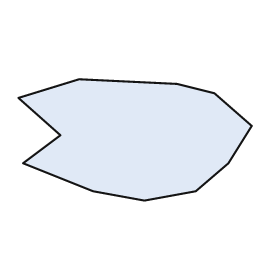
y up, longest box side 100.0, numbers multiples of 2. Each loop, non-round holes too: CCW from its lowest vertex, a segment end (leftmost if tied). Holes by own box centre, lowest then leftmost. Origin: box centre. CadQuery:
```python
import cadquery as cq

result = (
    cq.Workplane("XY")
    .moveTo(4.0, -26.0)
    .lineTo(26.0, -22.0)
    .lineTo(40.0, -10.0)
    .lineTo(50.0, 6.0)
    .lineTo(34.0, 20.0)
    .lineTo(18.0, 24.0)
    .lineTo(-24.0, 26.0)
    .lineTo(-50.0, 18.0)
    .lineTo(-32.0, 2.0)
    .lineTo(-48.0, -10.0)
    .lineTo(-18.0, -22.0)
    .close()
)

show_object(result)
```